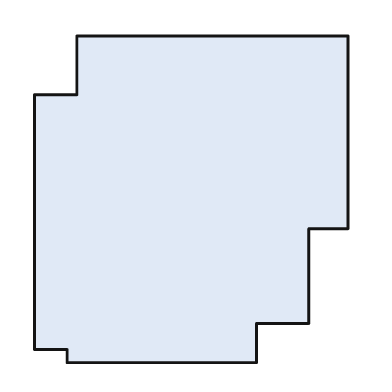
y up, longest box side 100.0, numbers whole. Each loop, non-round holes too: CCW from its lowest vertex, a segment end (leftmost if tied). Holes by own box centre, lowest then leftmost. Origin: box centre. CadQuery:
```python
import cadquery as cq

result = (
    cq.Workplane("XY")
    .moveTo(-38.0, -50.0)
    .lineTo(20.0, -50.0)
    .lineTo(20.0, -38.0)
    .lineTo(36.0, -38.0)
    .lineTo(36.0, -9.0)
    .lineTo(48.0, -9.0)
    .lineTo(48.0, 50.0)
    .lineTo(-35.0, 50.0)
    .lineTo(-35.0, 32.0)
    .lineTo(-48.0, 32.0)
    .lineTo(-48.0, -46.0)
    .lineTo(-38.0, -46.0)
    .close()
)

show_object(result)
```